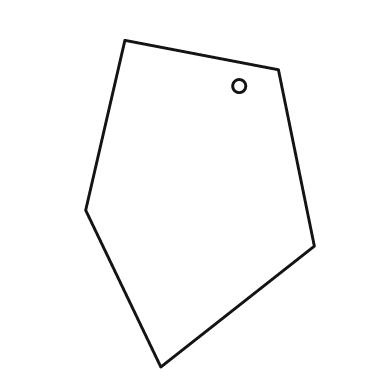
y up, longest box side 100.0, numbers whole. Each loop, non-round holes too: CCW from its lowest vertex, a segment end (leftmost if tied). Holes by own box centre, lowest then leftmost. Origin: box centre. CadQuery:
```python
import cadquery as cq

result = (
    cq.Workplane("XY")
    .moveTo(-12.0, -50.0)
    .lineTo(35.0, -13.0)
    .lineTo(24.0, 41.0)
    .lineTo(-23.0, 50.0)
    .lineTo(-35.0, -2.0)
    .close()
    .moveTo(12.0, 36.0)
    .circle(2.0)
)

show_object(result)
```